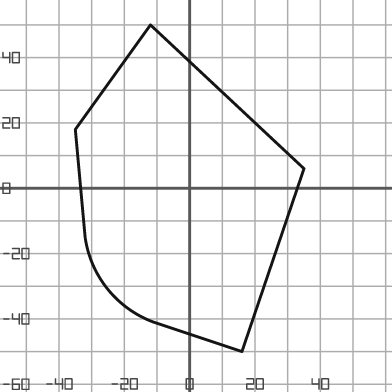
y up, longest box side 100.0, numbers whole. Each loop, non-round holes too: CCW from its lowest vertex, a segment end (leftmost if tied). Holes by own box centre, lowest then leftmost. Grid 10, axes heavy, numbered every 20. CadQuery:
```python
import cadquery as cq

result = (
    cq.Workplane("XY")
    .moveTo(16.0, -50.0)
    .lineTo(35.0, 6.0)
    .lineTo(-12.0, 50.0)
    .lineTo(-35.0, 18.0)
    .lineTo(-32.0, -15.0)
    .threePointArc((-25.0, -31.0), (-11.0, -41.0))
    .close()
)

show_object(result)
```